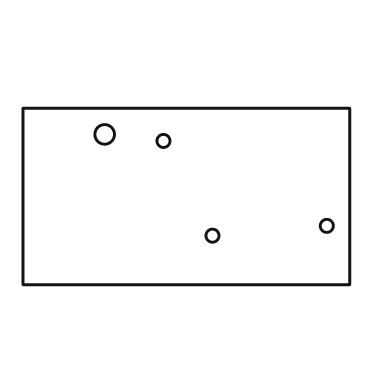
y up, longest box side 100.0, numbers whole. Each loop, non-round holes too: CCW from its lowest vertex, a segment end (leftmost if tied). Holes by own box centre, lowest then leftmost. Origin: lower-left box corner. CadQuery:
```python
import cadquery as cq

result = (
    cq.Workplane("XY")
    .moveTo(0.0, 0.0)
    .lineTo(100.0, 0.0)
    .lineTo(100.0, 54.0)
    .lineTo(0.0, 54.0)
    .close()
    .moveTo(58.0, 15.0)
    .circle(2.0)
    .moveTo(93.0, 18.0)
    .circle(2.0)
    .moveTo(43.0, 44.0)
    .circle(2.0)
    .moveTo(25.0, 46.0)
    .circle(3.0)
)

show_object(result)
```